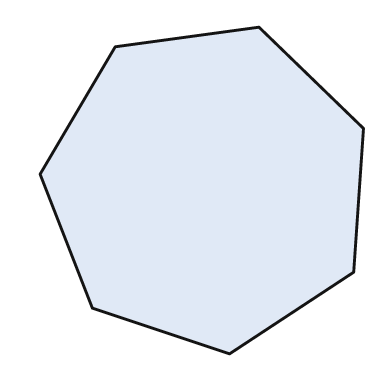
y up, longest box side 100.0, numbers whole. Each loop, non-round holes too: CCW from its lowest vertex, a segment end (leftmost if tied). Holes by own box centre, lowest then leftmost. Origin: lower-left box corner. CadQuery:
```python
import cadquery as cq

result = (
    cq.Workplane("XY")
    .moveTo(58.0, 0.0)
    .lineTo(96.0, 25.0)
    .lineTo(99.0, 69.0)
    .lineTo(67.0, 100.0)
    .lineTo(23.0, 94.0)
    .lineTo(0.0, 55.0)
    .lineTo(16.0, 14.0)
    .close()
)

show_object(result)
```